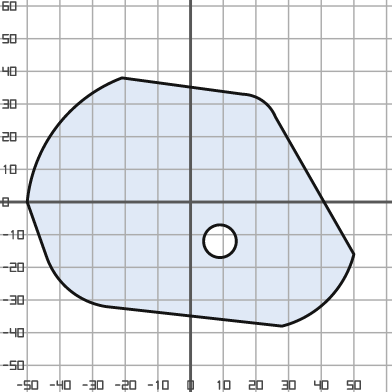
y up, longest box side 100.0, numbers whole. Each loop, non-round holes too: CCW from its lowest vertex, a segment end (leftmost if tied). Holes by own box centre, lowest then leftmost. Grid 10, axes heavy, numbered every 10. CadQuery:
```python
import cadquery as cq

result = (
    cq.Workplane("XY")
    .moveTo(28.0, -38.0)
    .threePointArc((42.0, -30.0), (50.0, -16.0))
    .lineTo(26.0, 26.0)
    .threePointArc((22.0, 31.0), (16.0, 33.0))
    .lineTo(-21.0, 38.0)
    .threePointArc((-41.0, 23.0), (-50.0, 0.0))
    .lineTo(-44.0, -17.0)
    .threePointArc((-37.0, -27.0), (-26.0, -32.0))
    .close()
    .moveTo(9.0, -12.0)
    .circle(5.0)
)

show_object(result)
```